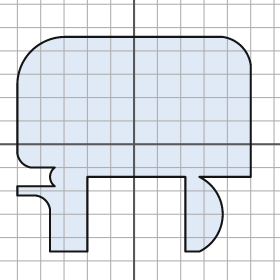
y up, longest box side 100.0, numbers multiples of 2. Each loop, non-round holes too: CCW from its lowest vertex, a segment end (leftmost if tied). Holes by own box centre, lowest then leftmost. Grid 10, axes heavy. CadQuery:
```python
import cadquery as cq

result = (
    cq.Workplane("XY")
    .moveTo(-36.0, -46.0)
    .lineTo(-20.0, -46.0)
    .lineTo(-20.0, -14.0)
    .lineTo(22.0, -14.0)
    .lineTo(22.0, -46.0)
    .lineTo(28.0, -46.0)
    .threePointArc((38.0, -30.0), (28.0, -14.0))
    .lineTo(50.0, -14.0)
    .lineTo(50.0, 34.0)
    .threePointArc((46.0, 42.0), (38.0, 46.0))
    .lineTo(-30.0, 46.0)
    .threePointArc((-44.0, 40.0), (-50.0, 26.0))
    .lineTo(-50.0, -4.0)
    .threePointArc((-48.0, -8.0), (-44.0, -10.0))
    .lineTo(-34.0, -10.0)
    .threePointArc((-36.0, -14.0), (-34.0, -18.0))
    .lineTo(-50.0, -18.0)
    .lineTo(-50.0, -22.0)
    .lineTo(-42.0, -22.0)
    .threePointArc((-38.0, -24.0), (-36.0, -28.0))
    .close()
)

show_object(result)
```